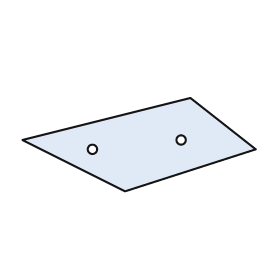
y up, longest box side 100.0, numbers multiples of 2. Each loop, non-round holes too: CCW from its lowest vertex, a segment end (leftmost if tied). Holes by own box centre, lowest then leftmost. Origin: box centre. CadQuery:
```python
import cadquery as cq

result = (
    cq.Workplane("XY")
    .moveTo(-6.0, -20.0)
    .lineTo(50.0, -2.0)
    .lineTo(22.0, 20.0)
    .lineTo(-50.0, 2.0)
    .close()
    .moveTo(-20.0, -2.0)
    .circle(2.0)
    .moveTo(18.0, 2.0)
    .circle(2.0)
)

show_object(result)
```